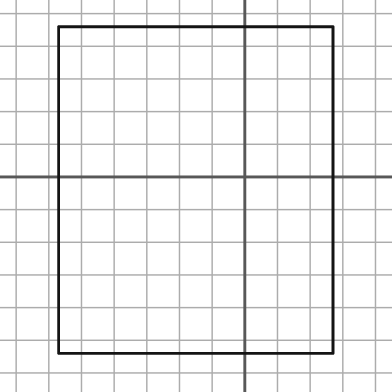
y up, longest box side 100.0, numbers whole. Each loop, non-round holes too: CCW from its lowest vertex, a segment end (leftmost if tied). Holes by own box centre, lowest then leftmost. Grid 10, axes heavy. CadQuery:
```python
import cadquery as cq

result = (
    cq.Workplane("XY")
    .moveTo(-57.0, -54.0)
    .lineTo(27.0, -54.0)
    .lineTo(27.0, 46.0)
    .lineTo(-57.0, 46.0)
    .close()
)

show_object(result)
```